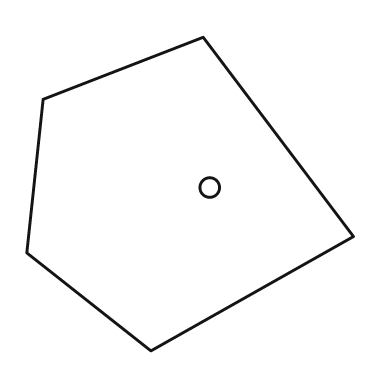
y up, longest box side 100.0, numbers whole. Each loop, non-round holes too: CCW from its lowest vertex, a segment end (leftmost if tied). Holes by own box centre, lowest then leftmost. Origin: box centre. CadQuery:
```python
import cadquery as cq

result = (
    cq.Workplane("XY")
    .moveTo(-12.0, -48.0)
    .lineTo(50.0, -13.0)
    .lineTo(4.0, 48.0)
    .lineTo(-45.0, 29.0)
    .lineTo(-50.0, -18.0)
    .close()
    .moveTo(6.0, 2.0)
    .circle(3.0)
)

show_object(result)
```